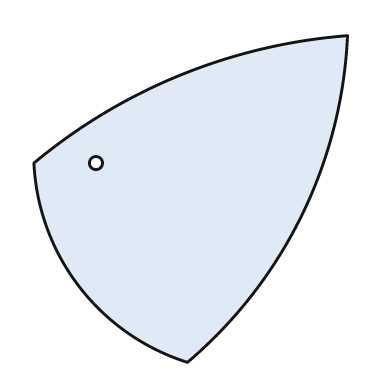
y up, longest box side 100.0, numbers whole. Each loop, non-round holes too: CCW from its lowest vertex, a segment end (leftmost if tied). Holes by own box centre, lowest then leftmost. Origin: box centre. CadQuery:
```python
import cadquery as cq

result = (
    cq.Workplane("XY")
    .moveTo(-1.0, -50.0)
    .threePointArc((34.0, -5.0), (48.0, 50.0))
    .threePointArc((-3.0, 38.0), (-48.0, 11.0))
    .threePointArc((-34.0, -27.0), (-1.0, -50.0))
    .close()
    .moveTo(-29.0, 11.0)
    .circle(2.0)
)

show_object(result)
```